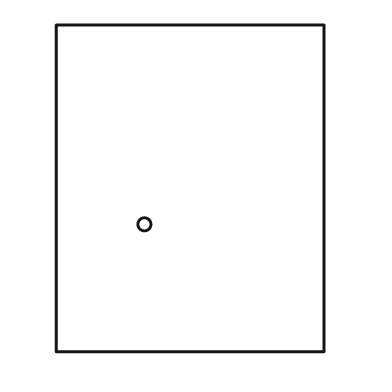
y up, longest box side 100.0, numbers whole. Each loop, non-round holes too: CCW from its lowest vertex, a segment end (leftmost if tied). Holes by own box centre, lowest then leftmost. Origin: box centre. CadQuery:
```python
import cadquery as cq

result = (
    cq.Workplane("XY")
    .moveTo(-41.0, -50.0)
    .lineTo(41.0, -50.0)
    .lineTo(41.0, 50.0)
    .lineTo(-41.0, 50.0)
    .close()
    .moveTo(-14.0, -11.0)
    .circle(2.0)
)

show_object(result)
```